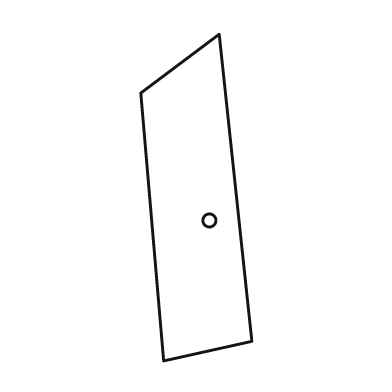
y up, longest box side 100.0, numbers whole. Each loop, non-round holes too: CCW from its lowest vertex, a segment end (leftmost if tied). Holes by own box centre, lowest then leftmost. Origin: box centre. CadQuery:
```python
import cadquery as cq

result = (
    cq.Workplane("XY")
    .moveTo(-10.0, -50.0)
    .lineTo(17.0, -44.0)
    .lineTo(7.0, 50.0)
    .lineTo(-17.0, 32.0)
    .close()
    .moveTo(4.0, -7.0)
    .circle(2.0)
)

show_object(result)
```